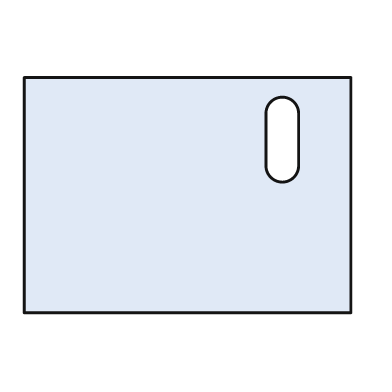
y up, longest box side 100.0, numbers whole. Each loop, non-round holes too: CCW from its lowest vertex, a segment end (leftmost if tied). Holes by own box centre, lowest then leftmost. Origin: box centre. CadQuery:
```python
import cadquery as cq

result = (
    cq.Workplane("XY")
    .moveTo(-50.0, -36.0)
    .lineTo(50.0, -36.0)
    .lineTo(50.0, 36.0)
    .lineTo(-50.0, 36.0)
    .close()
    .moveTo(24.0, 9.0)
    .threePointArc((29.0, 4.0), (34.0, 9.0))
    .lineTo(34.0, 25.0)
    .threePointArc((29.0, 30.0), (24.0, 25.0))
    .close()
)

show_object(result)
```